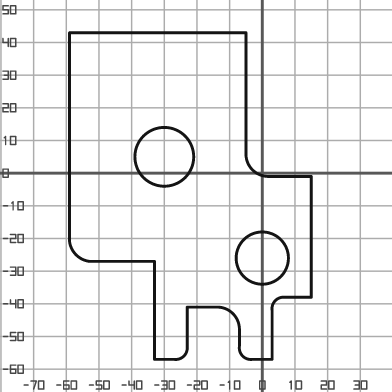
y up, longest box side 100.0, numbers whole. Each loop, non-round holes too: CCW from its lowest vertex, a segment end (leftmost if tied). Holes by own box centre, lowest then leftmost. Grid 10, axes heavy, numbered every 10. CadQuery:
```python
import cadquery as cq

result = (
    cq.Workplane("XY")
    .moveTo(-33.0, -57.0)
    .lineTo(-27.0, -57.0)
    .threePointArc((-24.0, -56.0), (-23.0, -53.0))
    .lineTo(-23.0, -41.0)
    .lineTo(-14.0, -41.0)
    .threePointArc((-9.0, -43.0), (-7.0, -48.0))
    .lineTo(-7.0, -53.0)
    .threePointArc((-6.0, -56.0), (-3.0, -57.0))
    .lineTo(3.0, -57.0)
    .lineTo(3.0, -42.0)
    .threePointArc((4.0, -39.0), (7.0, -38.0))
    .lineTo(15.0, -38.0)
    .lineTo(15.0, -1.0)
    .lineTo(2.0, -1.0)
    .threePointArc((-3.0, 1.0), (-5.0, 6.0))
    .lineTo(-5.0, 43.0)
    .lineTo(-59.0, 43.0)
    .lineTo(-59.0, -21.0)
    .threePointArc((-57.0, -25.0), (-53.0, -27.0))
    .lineTo(-33.0, -27.0)
    .close()
    .moveTo(0.0, -26.0)
    .circle(8.0)
    .moveTo(-30.0, 5.0)
    .circle(9.0)
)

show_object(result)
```